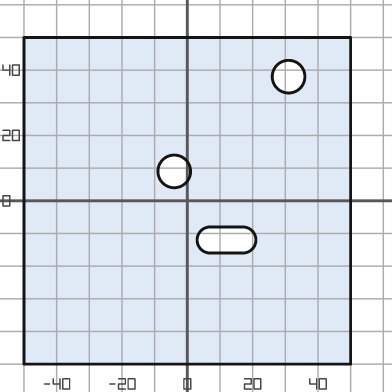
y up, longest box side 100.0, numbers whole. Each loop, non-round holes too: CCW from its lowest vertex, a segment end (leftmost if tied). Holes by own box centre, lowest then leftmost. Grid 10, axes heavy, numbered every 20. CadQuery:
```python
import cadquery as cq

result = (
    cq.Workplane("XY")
    .moveTo(-50.0, -50.0)
    .lineTo(50.0, -50.0)
    .lineTo(50.0, 50.0)
    .lineTo(-50.0, 50.0)
    .close()
    .moveTo(7.0, -16.0)
    .lineTo(17.0, -16.0)
    .threePointArc((21.0, -12.0), (17.0, -8.0))
    .lineTo(7.0, -8.0)
    .threePointArc((3.0, -12.0), (7.0, -16.0))
    .close()
    .moveTo(-4.0, 9.0)
    .circle(5.0)
    .moveTo(31.0, 38.0)
    .circle(5.0)
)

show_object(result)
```